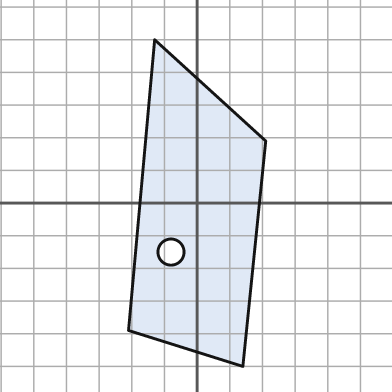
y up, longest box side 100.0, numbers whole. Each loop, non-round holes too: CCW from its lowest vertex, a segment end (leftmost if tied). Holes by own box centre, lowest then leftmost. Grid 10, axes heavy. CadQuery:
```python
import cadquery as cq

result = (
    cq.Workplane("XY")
    .moveTo(14.0, -50.0)
    .lineTo(21.0, 19.0)
    .lineTo(-13.0, 50.0)
    .lineTo(-21.0, -39.0)
    .close()
    .moveTo(-8.0, -15.0)
    .circle(4.0)
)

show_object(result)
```